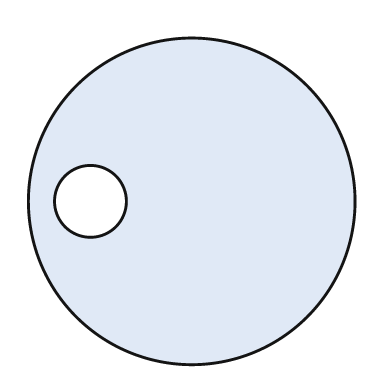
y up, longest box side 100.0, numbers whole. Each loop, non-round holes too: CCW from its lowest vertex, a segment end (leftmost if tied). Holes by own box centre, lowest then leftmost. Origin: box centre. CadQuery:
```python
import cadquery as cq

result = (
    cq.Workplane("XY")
    .moveTo(0.0, 0.0)
    .circle(50.0)
    .moveTo(-31.0, 0.0)
    .circle(11.0)
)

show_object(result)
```